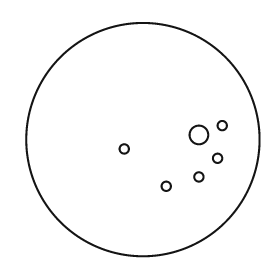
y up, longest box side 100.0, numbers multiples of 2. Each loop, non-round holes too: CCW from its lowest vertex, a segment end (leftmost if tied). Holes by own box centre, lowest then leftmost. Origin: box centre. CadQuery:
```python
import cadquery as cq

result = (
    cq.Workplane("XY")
    .moveTo(0.0, 0.0)
    .circle(50.0)
    .moveTo(10.0, -20.0)
    .circle(2.0)
    .moveTo(24.0, -16.0)
    .circle(2.0)
    .moveTo(32.0, -8.0)
    .circle(2.0)
    .moveTo(-8.0, -4.0)
    .circle(2.0)
    .moveTo(24.0, 2.0)
    .circle(4.0)
    .moveTo(34.0, 6.0)
    .circle(2.0)
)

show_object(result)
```